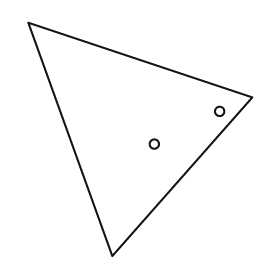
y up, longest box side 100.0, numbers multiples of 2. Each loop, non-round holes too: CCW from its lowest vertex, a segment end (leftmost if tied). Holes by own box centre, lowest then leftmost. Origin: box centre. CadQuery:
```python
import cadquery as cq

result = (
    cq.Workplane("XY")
    .moveTo(-12.0, -50.0)
    .lineTo(48.0, 18.0)
    .lineTo(-48.0, 50.0)
    .close()
    .moveTo(6.0, -2.0)
    .circle(2.0)
    .moveTo(34.0, 12.0)
    .circle(2.0)
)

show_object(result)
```